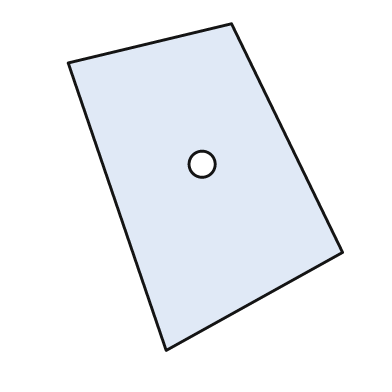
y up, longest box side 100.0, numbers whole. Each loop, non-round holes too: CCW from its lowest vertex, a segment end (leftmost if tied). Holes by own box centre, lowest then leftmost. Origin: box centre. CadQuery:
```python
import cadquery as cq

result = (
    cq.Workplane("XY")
    .moveTo(-12.0, -50.0)
    .lineTo(42.0, -20.0)
    .lineTo(8.0, 50.0)
    .lineTo(-42.0, 38.0)
    .close()
    .moveTo(-1.0, 7.0)
    .circle(4.0)
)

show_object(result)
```